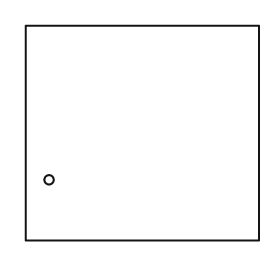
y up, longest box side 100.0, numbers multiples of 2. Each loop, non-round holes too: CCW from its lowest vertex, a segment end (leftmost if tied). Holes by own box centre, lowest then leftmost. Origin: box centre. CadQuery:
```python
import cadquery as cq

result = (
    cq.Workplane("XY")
    .moveTo(-50.0, -46.0)
    .lineTo(50.0, -46.0)
    .lineTo(50.0, 46.0)
    .lineTo(-50.0, 46.0)
    .close()
    .moveTo(-40.0, -20.0)
    .circle(2.0)
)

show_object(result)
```